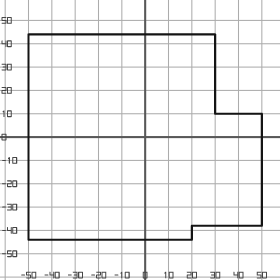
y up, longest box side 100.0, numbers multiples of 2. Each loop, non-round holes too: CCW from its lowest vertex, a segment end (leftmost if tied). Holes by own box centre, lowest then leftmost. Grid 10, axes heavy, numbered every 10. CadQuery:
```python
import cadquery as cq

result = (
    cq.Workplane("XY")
    .moveTo(-50.0, -44.0)
    .lineTo(20.0, -44.0)
    .lineTo(20.0, -38.0)
    .lineTo(50.0, -38.0)
    .lineTo(50.0, 10.0)
    .lineTo(30.0, 10.0)
    .lineTo(30.0, 44.0)
    .lineTo(-50.0, 44.0)
    .close()
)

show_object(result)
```